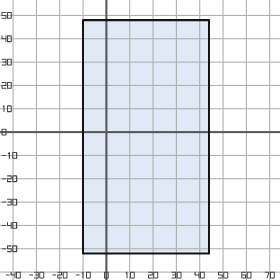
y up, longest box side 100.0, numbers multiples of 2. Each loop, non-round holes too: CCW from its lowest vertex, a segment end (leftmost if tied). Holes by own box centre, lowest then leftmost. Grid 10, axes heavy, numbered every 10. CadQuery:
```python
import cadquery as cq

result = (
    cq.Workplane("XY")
    .moveTo(-10.0, -52.0)
    .lineTo(44.0, -52.0)
    .lineTo(44.0, 48.0)
    .lineTo(-10.0, 48.0)
    .close()
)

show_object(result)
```